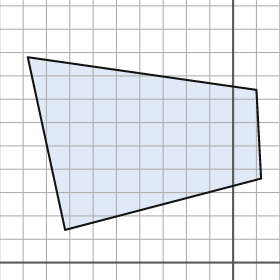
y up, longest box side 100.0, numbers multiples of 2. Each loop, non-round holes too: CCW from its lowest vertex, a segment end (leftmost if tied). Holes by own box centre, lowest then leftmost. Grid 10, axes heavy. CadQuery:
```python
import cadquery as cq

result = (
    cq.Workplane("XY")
    .moveTo(-72.0, 14.0)
    .lineTo(12.0, 36.0)
    .lineTo(10.0, 74.0)
    .lineTo(-88.0, 88.0)
    .close()
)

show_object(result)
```